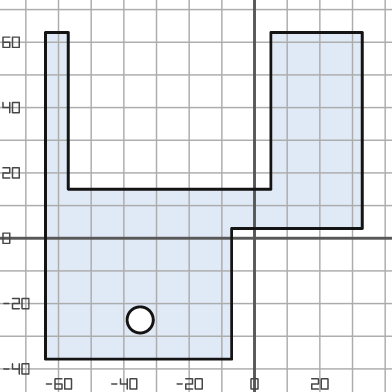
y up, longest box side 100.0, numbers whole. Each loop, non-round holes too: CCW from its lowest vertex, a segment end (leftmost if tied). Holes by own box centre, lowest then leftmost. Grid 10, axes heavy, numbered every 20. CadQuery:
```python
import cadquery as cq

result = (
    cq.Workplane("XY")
    .moveTo(-64.0, -37.0)
    .lineTo(-7.0, -37.0)
    .lineTo(-7.0, 3.0)
    .lineTo(33.0, 3.0)
    .lineTo(33.0, 63.0)
    .lineTo(5.0, 63.0)
    .lineTo(5.0, 15.0)
    .lineTo(-57.0, 15.0)
    .lineTo(-57.0, 63.0)
    .lineTo(-64.0, 63.0)
    .close()
    .moveTo(-35.0, -25.0)
    .circle(4.0)
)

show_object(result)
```